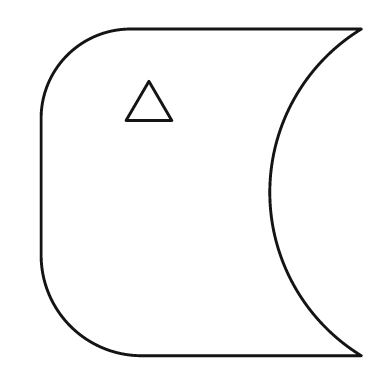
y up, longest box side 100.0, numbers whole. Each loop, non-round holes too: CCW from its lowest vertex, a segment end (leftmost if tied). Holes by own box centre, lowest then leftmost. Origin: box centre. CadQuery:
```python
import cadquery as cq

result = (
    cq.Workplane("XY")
    .moveTo(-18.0, -50.0)
    .lineTo(49.0, -50.0)
    .threePointArc((21.0, 0.0), (49.0, 50.0))
    .lineTo(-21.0, 50.0)
    .threePointArc((-41.0, 42.0), (-49.0, 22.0))
    .lineTo(-49.0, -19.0)
    .threePointArc((-40.0, -41.0), (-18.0, -50.0))
    .close()
    .moveTo(-23.0, 22.0)
    .lineTo(-9.0, 22.0)
    .lineTo(-16.0, 34.0)
    .close()
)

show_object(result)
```